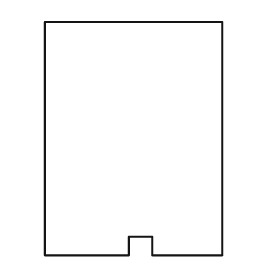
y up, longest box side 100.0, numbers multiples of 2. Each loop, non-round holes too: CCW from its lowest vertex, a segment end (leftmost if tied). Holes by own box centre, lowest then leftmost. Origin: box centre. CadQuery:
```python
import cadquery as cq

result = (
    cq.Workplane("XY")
    .moveTo(-38.0, -50.0)
    .lineTo(-2.0, -50.0)
    .lineTo(-2.0, -42.0)
    .lineTo(8.0, -42.0)
    .lineTo(8.0, -50.0)
    .lineTo(38.0, -50.0)
    .lineTo(38.0, 50.0)
    .lineTo(-38.0, 50.0)
    .close()
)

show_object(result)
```